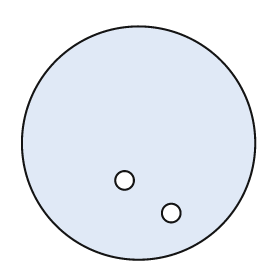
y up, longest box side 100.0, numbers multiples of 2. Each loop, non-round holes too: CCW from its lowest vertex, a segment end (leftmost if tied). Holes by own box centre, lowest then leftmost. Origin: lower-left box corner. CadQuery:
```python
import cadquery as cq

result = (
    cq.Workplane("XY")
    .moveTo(50.0, 50.0)
    .circle(50.0)
    .moveTo(64.0, 20.0)
    .circle(4.0)
    .moveTo(44.0, 34.0)
    .circle(4.0)
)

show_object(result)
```